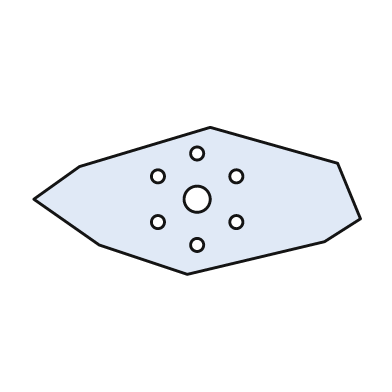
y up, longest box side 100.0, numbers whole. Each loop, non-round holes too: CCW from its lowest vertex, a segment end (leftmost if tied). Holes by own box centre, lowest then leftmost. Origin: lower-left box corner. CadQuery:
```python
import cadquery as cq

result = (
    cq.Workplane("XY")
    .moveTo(47.0, 0.0)
    .lineTo(89.0, 10.0)
    .lineTo(100.0, 17.0)
    .lineTo(93.0, 34.0)
    .lineTo(54.0, 45.0)
    .lineTo(14.0, 33.0)
    .lineTo(0.0, 23.0)
    .lineTo(20.0, 9.0)
    .close()
    .moveTo(50.0, 9.0)
    .circle(2.0)
    .moveTo(38.0, 16.0)
    .circle(2.0)
    .moveTo(62.0, 16.0)
    .circle(2.0)
    .moveTo(50.0, 23.0)
    .circle(4.0)
    .moveTo(38.0, 30.0)
    .circle(2.0)
    .moveTo(62.0, 30.0)
    .circle(2.0)
    .moveTo(50.0, 37.0)
    .circle(2.0)
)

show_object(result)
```